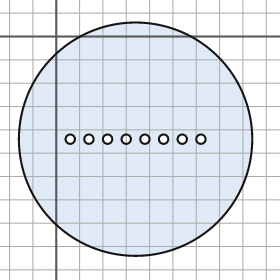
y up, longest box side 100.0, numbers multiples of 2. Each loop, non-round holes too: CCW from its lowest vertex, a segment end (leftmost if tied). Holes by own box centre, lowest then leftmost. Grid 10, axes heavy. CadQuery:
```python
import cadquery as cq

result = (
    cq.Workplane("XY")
    .moveTo(34.0, -44.0)
    .circle(50.0)
    .moveTo(6.0, -44.0)
    .circle(2.0)
    .moveTo(14.0, -44.0)
    .circle(2.0)
    .moveTo(22.0, -44.0)
    .circle(2.0)
    .moveTo(30.0, -44.0)
    .circle(2.0)
    .moveTo(38.0, -44.0)
    .circle(2.0)
    .moveTo(46.0, -44.0)
    .circle(2.0)
    .moveTo(54.0, -44.0)
    .circle(2.0)
    .moveTo(62.0, -44.0)
    .circle(2.0)
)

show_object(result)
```